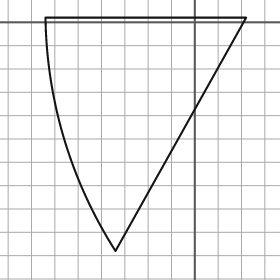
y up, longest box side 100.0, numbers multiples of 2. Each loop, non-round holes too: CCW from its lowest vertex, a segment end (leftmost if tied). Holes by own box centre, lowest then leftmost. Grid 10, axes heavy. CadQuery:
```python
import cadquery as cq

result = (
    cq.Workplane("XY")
    .moveTo(-34.0, -98.0)
    .lineTo(22.0, 2.0)
    .lineTo(-64.0, 2.0)
    .threePointArc((-56.0, -50.0), (-34.0, -98.0))
    .close()
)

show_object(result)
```